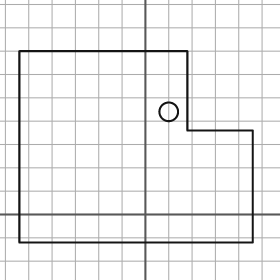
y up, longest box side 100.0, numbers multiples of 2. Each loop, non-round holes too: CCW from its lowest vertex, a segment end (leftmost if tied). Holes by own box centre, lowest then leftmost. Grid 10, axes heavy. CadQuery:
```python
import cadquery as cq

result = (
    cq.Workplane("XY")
    .moveTo(-54.0, -12.0)
    .lineTo(46.0, -12.0)
    .lineTo(46.0, 36.0)
    .lineTo(18.0, 36.0)
    .lineTo(18.0, 70.0)
    .lineTo(-54.0, 70.0)
    .close()
    .moveTo(10.0, 44.0)
    .circle(4.0)
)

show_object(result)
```